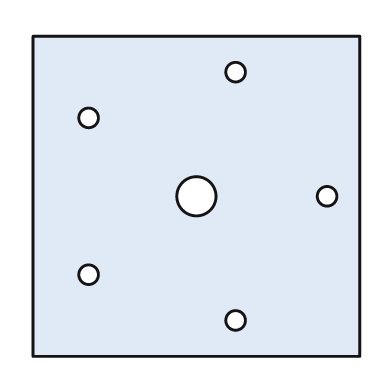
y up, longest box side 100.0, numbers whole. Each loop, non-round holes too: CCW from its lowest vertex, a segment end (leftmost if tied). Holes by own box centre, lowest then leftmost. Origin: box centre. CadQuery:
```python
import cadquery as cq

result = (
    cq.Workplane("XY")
    .moveTo(-50.0, -49.0)
    .lineTo(50.0, -49.0)
    .lineTo(50.0, 49.0)
    .lineTo(-50.0, 49.0)
    .close()
    .moveTo(12.0, -38.0)
    .circle(3.0)
    .moveTo(-33.0, -24.0)
    .circle(3.0)
    .moveTo(0.0, 0.0)
    .circle(6.0)
    .moveTo(40.0, 0.0)
    .circle(3.0)
    .moveTo(-33.0, 24.0)
    .circle(3.0)
    .moveTo(12.0, 38.0)
    .circle(3.0)
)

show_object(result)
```